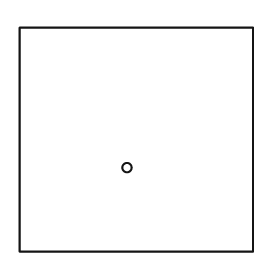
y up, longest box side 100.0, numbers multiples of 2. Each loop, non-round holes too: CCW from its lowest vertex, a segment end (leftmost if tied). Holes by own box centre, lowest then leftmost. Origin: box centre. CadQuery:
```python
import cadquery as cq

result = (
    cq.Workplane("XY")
    .moveTo(-50.0, -48.0)
    .lineTo(50.0, -48.0)
    .lineTo(50.0, 48.0)
    .lineTo(-50.0, 48.0)
    .close()
    .moveTo(-4.0, -12.0)
    .circle(2.0)
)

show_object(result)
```